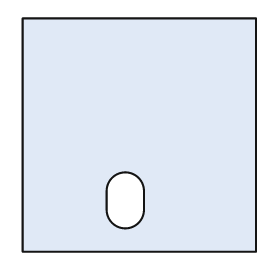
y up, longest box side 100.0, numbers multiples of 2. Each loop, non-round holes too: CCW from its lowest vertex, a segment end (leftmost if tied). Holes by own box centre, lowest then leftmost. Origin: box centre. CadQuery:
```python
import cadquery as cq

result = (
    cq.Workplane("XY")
    .moveTo(-50.0, -50.0)
    .lineTo(50.0, -50.0)
    .lineTo(50.0, 50.0)
    .lineTo(-50.0, 50.0)
    .close()
    .moveTo(-14.0, -32.0)
    .threePointArc((-6.0, -40.0), (2.0, -32.0))
    .lineTo(2.0, -24.0)
    .threePointArc((-6.0, -16.0), (-14.0, -24.0))
    .close()
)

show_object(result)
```